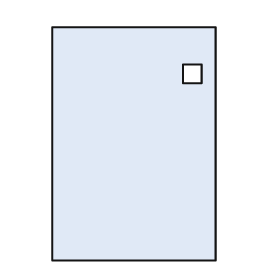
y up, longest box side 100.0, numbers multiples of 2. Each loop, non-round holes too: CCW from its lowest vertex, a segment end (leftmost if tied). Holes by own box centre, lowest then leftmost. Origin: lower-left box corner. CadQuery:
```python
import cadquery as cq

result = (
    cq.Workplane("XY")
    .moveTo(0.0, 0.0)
    .lineTo(70.0, 0.0)
    .lineTo(70.0, 100.0)
    .lineTo(0.0, 100.0)
    .close()
    .moveTo(56.0, 76.0)
    .lineTo(64.0, 76.0)
    .lineTo(64.0, 84.0)
    .lineTo(56.0, 84.0)
    .close()
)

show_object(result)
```